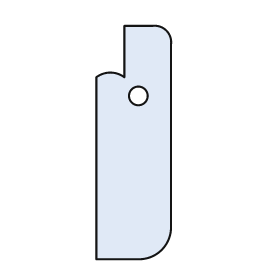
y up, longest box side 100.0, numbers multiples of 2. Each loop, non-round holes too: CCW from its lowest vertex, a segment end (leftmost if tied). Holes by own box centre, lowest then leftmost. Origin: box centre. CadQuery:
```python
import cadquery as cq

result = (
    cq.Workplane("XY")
    .moveTo(-16.0, -50.0)
    .lineTo(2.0, -50.0)
    .threePointArc((12.0, -46.0), (16.0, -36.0))
    .lineTo(16.0, 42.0)
    .threePointArc((14.0, 48.0), (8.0, 50.0))
    .lineTo(-4.0, 50.0)
    .lineTo(-4.0, 28.0)
    .threePointArc((-10.0, 30.0), (-16.0, 28.0))
    .close()
    .moveTo(2.0, 20.0)
    .circle(4.0)
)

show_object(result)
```